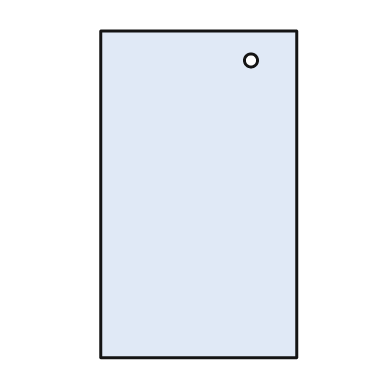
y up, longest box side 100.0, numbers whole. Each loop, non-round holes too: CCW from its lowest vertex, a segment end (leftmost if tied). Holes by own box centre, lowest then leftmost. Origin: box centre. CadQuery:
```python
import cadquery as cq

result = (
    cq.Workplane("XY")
    .moveTo(-30.0, -50.0)
    .lineTo(30.0, -50.0)
    .lineTo(30.0, 50.0)
    .lineTo(-30.0, 50.0)
    .close()
    .moveTo(16.0, 41.0)
    .circle(2.0)
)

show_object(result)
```